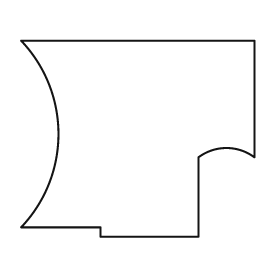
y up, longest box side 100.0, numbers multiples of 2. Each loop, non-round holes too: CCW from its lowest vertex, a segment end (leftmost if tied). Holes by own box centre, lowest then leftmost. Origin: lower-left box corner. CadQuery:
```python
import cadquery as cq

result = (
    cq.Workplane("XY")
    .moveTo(34.0, 0.0)
    .lineTo(76.0, 0.0)
    .lineTo(76.0, 34.0)
    .threePointArc((88.0, 38.0), (100.0, 34.0))
    .lineTo(100.0, 84.0)
    .lineTo(0.0, 84.0)
    .threePointArc((16.0, 44.0), (0.0, 4.0))
    .lineTo(34.0, 4.0)
    .close()
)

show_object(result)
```